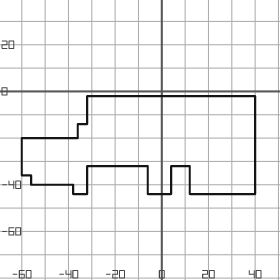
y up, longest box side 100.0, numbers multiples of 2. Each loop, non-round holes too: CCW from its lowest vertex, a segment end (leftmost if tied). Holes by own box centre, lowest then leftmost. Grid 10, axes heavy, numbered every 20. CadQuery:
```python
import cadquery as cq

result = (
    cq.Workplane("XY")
    .moveTo(-38.0, -44.0)
    .lineTo(-32.0, -44.0)
    .lineTo(-32.0, -32.0)
    .lineTo(-6.0, -32.0)
    .lineTo(-6.0, -44.0)
    .lineTo(4.0, -44.0)
    .lineTo(4.0, -32.0)
    .lineTo(12.0, -32.0)
    .lineTo(12.0, -44.0)
    .lineTo(40.0, -44.0)
    .lineTo(40.0, -2.0)
    .lineTo(-32.0, -2.0)
    .lineTo(-32.0, -14.0)
    .lineTo(-36.0, -14.0)
    .lineTo(-36.0, -20.0)
    .lineTo(-60.0, -20.0)
    .lineTo(-60.0, -36.0)
    .lineTo(-56.0, -36.0)
    .lineTo(-56.0, -40.0)
    .lineTo(-38.0, -40.0)
    .close()
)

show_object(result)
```